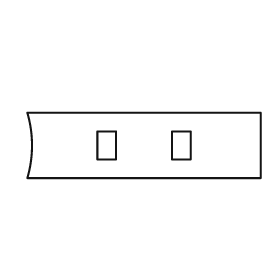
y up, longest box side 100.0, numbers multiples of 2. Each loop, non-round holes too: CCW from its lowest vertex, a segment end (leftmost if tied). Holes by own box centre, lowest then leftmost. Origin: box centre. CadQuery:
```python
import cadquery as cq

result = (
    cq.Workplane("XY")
    .moveTo(-50.0, -14.0)
    .lineTo(50.0, -14.0)
    .lineTo(50.0, 14.0)
    .lineTo(-50.0, 14.0)
    .threePointArc((-48.0, 0.0), (-50.0, -14.0))
    .close()
    .moveTo(-20.0, -6.0)
    .lineTo(-12.0, -6.0)
    .lineTo(-12.0, 6.0)
    .lineTo(-20.0, 6.0)
    .close()
    .moveTo(12.0, -6.0)
    .lineTo(20.0, -6.0)
    .lineTo(20.0, 6.0)
    .lineTo(12.0, 6.0)
    .close()
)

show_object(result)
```